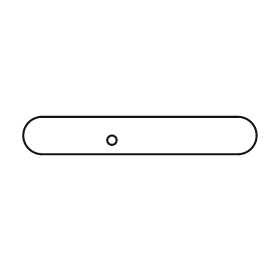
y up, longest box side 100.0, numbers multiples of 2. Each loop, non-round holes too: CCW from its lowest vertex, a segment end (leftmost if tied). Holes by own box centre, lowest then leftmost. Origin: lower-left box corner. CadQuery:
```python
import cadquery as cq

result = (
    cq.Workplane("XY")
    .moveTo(8.0, 0.0)
    .lineTo(92.0, 0.0)
    .threePointArc((100.0, 8.0), (92.0, 16.0))
    .lineTo(8.0, 16.0)
    .threePointArc((0.0, 8.0), (8.0, 0.0))
    .close()
    .moveTo(38.0, 6.0)
    .circle(2.0)
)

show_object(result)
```